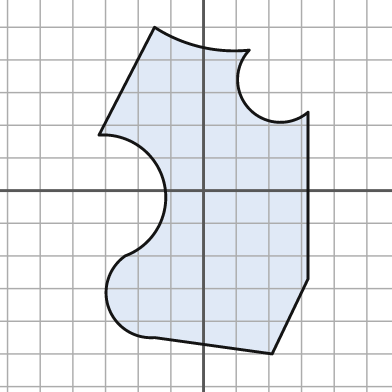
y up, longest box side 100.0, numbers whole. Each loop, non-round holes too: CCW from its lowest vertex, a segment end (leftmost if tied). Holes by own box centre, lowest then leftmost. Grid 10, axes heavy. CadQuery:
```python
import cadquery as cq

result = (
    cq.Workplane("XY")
    .moveTo(21.0, -50.0)
    .lineTo(32.0, -27.0)
    .lineTo(32.0, 24.0)
    .threePointArc((14.0, 25.0), (14.0, 43.0))
    .threePointArc((-1.0, 44.0), (-15.0, 50.0))
    .lineTo(-32.0, 17.0)
    .threePointArc((-12.0, 2.0), (-24.0, -20.0))
    .threePointArc((-29.0, -36.0), (-15.0, -45.0))
    .close()
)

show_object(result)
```